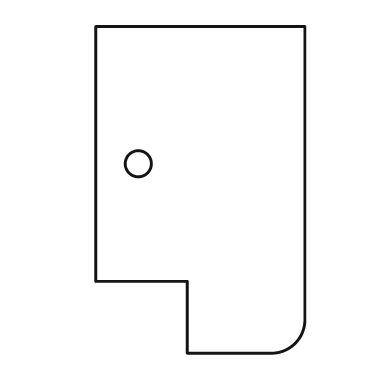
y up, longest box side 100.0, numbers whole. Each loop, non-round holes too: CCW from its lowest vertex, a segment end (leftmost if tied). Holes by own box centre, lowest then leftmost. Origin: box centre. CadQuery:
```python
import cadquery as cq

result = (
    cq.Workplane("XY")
    .moveTo(-4.0, -50.0)
    .lineTo(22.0, -50.0)
    .threePointArc((29.0, -47.0), (32.0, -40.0))
    .lineTo(32.0, 50.0)
    .lineTo(-32.0, 50.0)
    .lineTo(-32.0, -28.0)
    .lineTo(-4.0, -28.0)
    .close()
    .moveTo(-19.0, 8.0)
    .circle(4.0)
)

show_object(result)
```